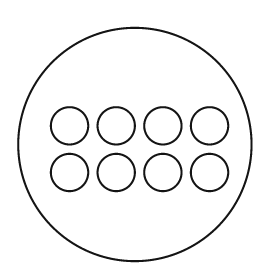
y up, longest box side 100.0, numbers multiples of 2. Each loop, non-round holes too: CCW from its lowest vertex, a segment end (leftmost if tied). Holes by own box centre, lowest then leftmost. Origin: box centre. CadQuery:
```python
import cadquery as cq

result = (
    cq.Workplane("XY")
    .moveTo(0.0, 0.0)
    .circle(50.0)
    .moveTo(-28.0, -12.0)
    .circle(8.0)
    .moveTo(-8.0, -12.0)
    .circle(8.0)
    .moveTo(12.0, -12.0)
    .circle(8.0)
    .moveTo(32.0, -12.0)
    .circle(8.0)
    .moveTo(-28.0, 8.0)
    .circle(8.0)
    .moveTo(-8.0, 8.0)
    .circle(8.0)
    .moveTo(12.0, 8.0)
    .circle(8.0)
    .moveTo(32.0, 8.0)
    .circle(8.0)
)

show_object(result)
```